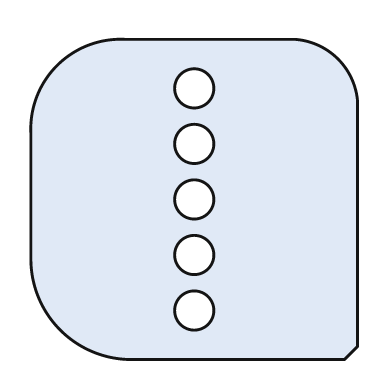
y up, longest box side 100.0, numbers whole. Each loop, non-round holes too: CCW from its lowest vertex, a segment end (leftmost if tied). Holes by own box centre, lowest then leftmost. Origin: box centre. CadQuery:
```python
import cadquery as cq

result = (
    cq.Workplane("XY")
    .moveTo(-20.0, -49.0)
    .lineTo(46.0, -49.0)
    .lineTo(50.0, -45.0)
    .lineTo(50.0, 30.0)
    .threePointArc((44.0, 43.0), (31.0, 49.0))
    .lineTo(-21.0, 49.0)
    .threePointArc((-42.0, 41.0), (-50.0, 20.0))
    .lineTo(-50.0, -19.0)
    .threePointArc((-41.0, -40.0), (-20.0, -49.0))
    .close()
    .moveTo(0.0, -34.0)
    .circle(6.0)
    .moveTo(0.0, -17.0)
    .circle(6.0)
    .moveTo(0.0, 0.0)
    .circle(6.0)
    .moveTo(0.0, 17.0)
    .circle(6.0)
    .moveTo(0.0, 34.0)
    .circle(6.0)
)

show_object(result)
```